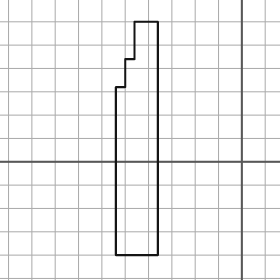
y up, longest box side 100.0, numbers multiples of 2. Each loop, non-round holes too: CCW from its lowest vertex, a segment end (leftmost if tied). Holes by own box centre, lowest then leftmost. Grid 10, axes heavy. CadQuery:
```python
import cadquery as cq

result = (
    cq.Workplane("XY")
    .moveTo(-54.0, -40.0)
    .lineTo(-36.0, -40.0)
    .lineTo(-36.0, 60.0)
    .lineTo(-46.0, 60.0)
    .lineTo(-46.0, 44.0)
    .lineTo(-50.0, 44.0)
    .lineTo(-50.0, 32.0)
    .lineTo(-54.0, 32.0)
    .close()
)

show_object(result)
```